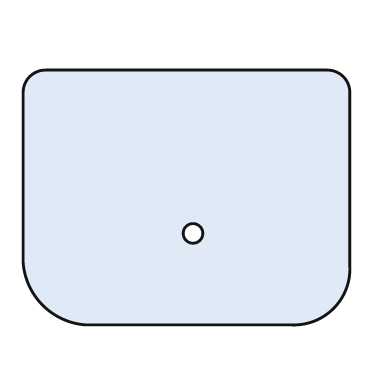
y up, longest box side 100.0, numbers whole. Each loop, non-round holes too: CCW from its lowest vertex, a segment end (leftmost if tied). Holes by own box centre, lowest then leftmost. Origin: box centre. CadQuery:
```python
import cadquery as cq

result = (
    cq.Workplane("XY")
    .moveTo(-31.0, -39.0)
    .lineTo(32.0, -39.0)
    .threePointArc((45.0, -34.0), (50.0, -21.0))
    .lineTo(50.0, 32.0)
    .threePointArc((48.0, 37.0), (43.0, 39.0))
    .lineTo(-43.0, 39.0)
    .threePointArc((-48.0, 37.0), (-50.0, 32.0))
    .lineTo(-50.0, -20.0)
    .threePointArc((-44.0, -33.0), (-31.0, -39.0))
    .close()
    .moveTo(2.0, -11.0)
    .circle(3.0)
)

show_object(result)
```